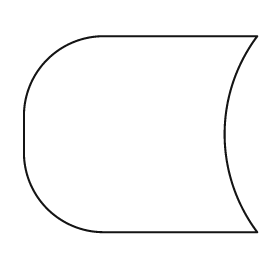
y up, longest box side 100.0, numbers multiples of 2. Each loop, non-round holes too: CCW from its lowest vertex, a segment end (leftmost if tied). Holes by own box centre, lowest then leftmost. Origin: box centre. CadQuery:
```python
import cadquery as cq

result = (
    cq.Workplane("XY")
    .moveTo(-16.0, -42.0)
    .lineTo(50.0, -42.0)
    .threePointArc((36.0, 0.0), (50.0, 42.0))
    .lineTo(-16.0, 42.0)
    .threePointArc((-40.0, 32.0), (-50.0, 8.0))
    .lineTo(-50.0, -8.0)
    .threePointArc((-40.0, -32.0), (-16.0, -42.0))
    .close()
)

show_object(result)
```